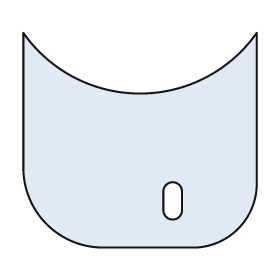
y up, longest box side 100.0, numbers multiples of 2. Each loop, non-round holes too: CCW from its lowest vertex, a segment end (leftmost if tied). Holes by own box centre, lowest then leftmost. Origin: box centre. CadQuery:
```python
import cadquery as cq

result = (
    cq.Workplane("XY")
    .moveTo(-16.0, -46.0)
    .lineTo(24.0, -46.0)
    .threePointArc((42.0, -38.0), (50.0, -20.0))
    .lineTo(50.0, 46.0)
    .threePointArc((0.0, 20.0), (-50.0, 46.0))
    .lineTo(-50.0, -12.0)
    .threePointArc((-40.0, -36.0), (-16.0, -46.0))
    .close()
    .moveTo(10.0, -30.0)
    .threePointArc((14.0, -34.0), (18.0, -30.0))
    .lineTo(18.0, -22.0)
    .threePointArc((14.0, -18.0), (10.0, -22.0))
    .close()
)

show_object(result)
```